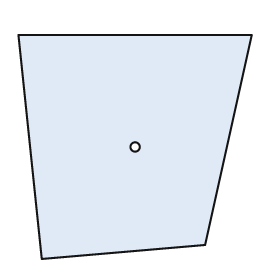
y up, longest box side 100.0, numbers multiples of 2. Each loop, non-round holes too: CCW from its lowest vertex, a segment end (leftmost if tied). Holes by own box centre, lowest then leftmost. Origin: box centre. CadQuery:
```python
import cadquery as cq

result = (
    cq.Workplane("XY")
    .moveTo(-40.0, -48.0)
    .lineTo(30.0, -42.0)
    .lineTo(50.0, 48.0)
    .lineTo(-50.0, 48.0)
    .close()
    .moveTo(0.0, 0.0)
    .circle(2.0)
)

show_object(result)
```